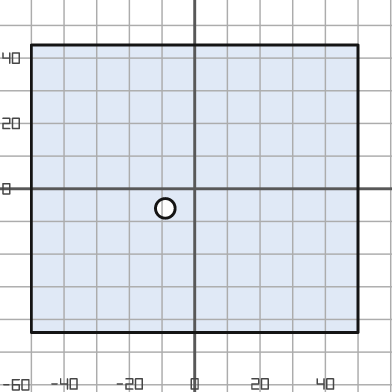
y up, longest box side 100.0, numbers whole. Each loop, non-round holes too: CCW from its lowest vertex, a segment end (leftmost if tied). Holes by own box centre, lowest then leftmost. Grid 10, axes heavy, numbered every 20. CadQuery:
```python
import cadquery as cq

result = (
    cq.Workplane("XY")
    .moveTo(-50.0, -44.0)
    .lineTo(50.0, -44.0)
    .lineTo(50.0, 44.0)
    .lineTo(-50.0, 44.0)
    .close()
    .moveTo(-9.0, -6.0)
    .circle(3.0)
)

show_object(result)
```